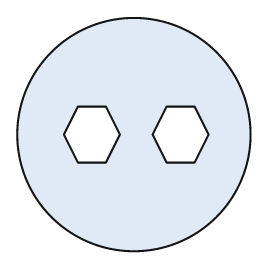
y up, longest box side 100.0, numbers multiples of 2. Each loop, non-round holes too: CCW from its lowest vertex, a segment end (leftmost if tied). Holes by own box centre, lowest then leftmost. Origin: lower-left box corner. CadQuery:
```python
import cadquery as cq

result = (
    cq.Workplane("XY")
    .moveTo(50.0, 50.0)
    .circle(50.0)
    .moveTo(26.0, 38.0)
    .lineTo(38.0, 38.0)
    .lineTo(44.0, 50.0)
    .lineTo(38.0, 62.0)
    .lineTo(26.0, 62.0)
    .lineTo(20.0, 50.0)
    .close()
    .moveTo(64.0, 38.0)
    .lineTo(76.0, 38.0)
    .lineTo(82.0, 50.0)
    .lineTo(76.0, 62.0)
    .lineTo(64.0, 62.0)
    .lineTo(58.0, 50.0)
    .close()
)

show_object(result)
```